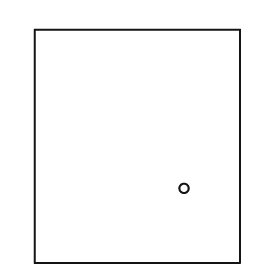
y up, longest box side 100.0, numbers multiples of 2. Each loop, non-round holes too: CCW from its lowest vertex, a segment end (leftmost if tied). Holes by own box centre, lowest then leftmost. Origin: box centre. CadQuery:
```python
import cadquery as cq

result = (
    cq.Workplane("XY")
    .moveTo(-44.0, -50.0)
    .lineTo(44.0, -50.0)
    .lineTo(44.0, 50.0)
    .lineTo(-44.0, 50.0)
    .close()
    .moveTo(20.0, -18.0)
    .circle(2.0)
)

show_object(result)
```